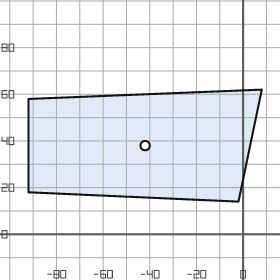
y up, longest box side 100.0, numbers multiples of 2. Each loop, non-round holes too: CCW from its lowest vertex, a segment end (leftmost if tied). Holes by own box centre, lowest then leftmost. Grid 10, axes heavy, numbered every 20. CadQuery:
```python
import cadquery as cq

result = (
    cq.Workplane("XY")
    .moveTo(-2.0, 14.0)
    .lineTo(8.0, 62.0)
    .lineTo(-92.0, 58.0)
    .lineTo(-92.0, 18.0)
    .close()
    .moveTo(-42.0, 38.0)
    .circle(2.0)
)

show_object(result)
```